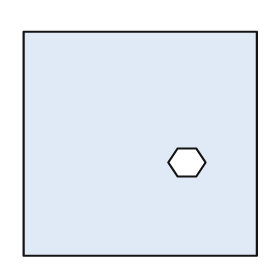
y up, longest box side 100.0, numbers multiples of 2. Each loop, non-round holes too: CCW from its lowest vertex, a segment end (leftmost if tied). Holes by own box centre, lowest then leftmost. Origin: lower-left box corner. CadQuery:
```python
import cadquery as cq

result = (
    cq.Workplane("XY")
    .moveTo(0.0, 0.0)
    .lineTo(100.0, 0.0)
    .lineTo(100.0, 96.0)
    .lineTo(0.0, 96.0)
    .close()
    .moveTo(66.0, 34.0)
    .lineTo(74.0, 34.0)
    .lineTo(78.0, 40.0)
    .lineTo(74.0, 46.0)
    .lineTo(66.0, 46.0)
    .lineTo(62.0, 40.0)
    .close()
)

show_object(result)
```